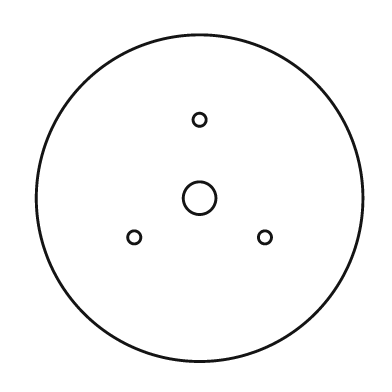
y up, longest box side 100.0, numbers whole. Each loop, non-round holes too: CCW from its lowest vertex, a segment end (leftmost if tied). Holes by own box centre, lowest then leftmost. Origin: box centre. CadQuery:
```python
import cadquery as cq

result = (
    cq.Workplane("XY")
    .moveTo(0.0, 0.0)
    .circle(50.0)
    .moveTo(-20.0, -12.0)
    .circle(2.0)
    .moveTo(20.0, -12.0)
    .circle(2.0)
    .moveTo(0.0, 0.0)
    .circle(5.0)
    .moveTo(0.0, 24.0)
    .circle(2.0)
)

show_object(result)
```